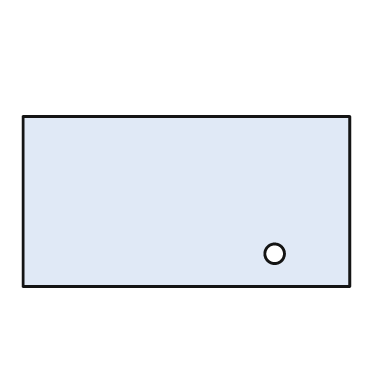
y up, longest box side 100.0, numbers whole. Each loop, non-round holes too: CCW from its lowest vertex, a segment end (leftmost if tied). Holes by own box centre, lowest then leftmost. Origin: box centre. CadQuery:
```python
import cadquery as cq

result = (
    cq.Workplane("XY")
    .moveTo(-50.0, -26.0)
    .lineTo(50.0, -26.0)
    .lineTo(50.0, 26.0)
    .lineTo(-50.0, 26.0)
    .close()
    .moveTo(27.0, -16.0)
    .circle(3.0)
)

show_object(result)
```